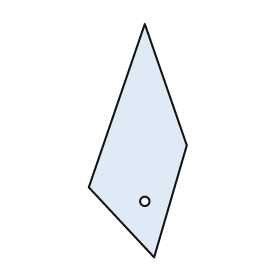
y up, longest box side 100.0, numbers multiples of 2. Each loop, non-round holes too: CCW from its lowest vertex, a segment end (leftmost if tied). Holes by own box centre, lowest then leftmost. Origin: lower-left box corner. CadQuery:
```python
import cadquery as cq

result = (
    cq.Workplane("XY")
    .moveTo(28.0, 0.0)
    .lineTo(42.0, 48.0)
    .lineTo(24.0, 100.0)
    .lineTo(0.0, 30.0)
    .close()
    .moveTo(24.0, 24.0)
    .circle(2.0)
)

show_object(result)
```